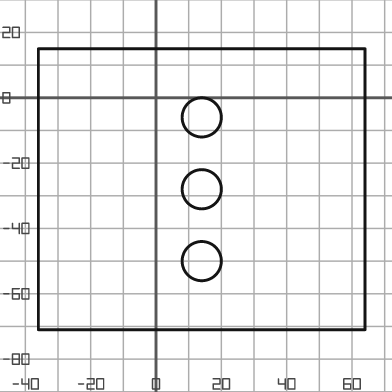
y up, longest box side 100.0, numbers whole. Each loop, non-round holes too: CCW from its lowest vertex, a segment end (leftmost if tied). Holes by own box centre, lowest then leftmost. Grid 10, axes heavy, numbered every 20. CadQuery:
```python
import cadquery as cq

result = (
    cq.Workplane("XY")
    .moveTo(-36.0, -71.0)
    .lineTo(64.0, -71.0)
    .lineTo(64.0, 15.0)
    .lineTo(-36.0, 15.0)
    .close()
    .moveTo(14.0, -50.0)
    .circle(6.0)
    .moveTo(14.0, -28.0)
    .circle(6.0)
    .moveTo(14.0, -6.0)
    .circle(6.0)
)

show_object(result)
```